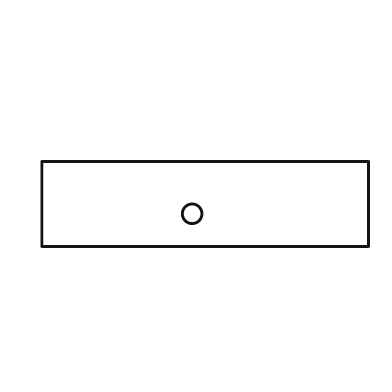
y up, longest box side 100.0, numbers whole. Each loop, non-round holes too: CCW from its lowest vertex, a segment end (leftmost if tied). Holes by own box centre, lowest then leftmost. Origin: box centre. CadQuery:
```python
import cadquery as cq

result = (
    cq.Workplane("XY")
    .moveTo(-50.0, -13.0)
    .lineTo(50.0, -13.0)
    .lineTo(50.0, 13.0)
    .lineTo(-50.0, 13.0)
    .close()
    .moveTo(-4.0, -3.0)
    .circle(3.0)
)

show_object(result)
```